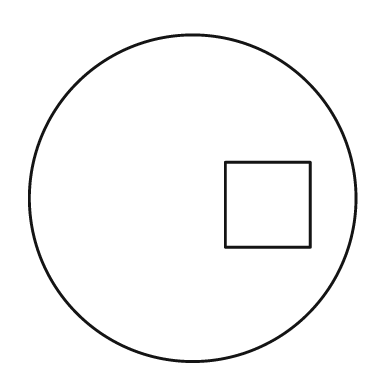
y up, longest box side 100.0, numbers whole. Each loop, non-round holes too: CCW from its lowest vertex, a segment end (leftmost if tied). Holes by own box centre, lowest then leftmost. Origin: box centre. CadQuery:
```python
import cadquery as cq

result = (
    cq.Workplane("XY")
    .moveTo(0.0, 0.0)
    .circle(50.0)
    .moveTo(10.0, -15.0)
    .lineTo(36.0, -15.0)
    .lineTo(36.0, 11.0)
    .lineTo(10.0, 11.0)
    .close()
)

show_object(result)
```